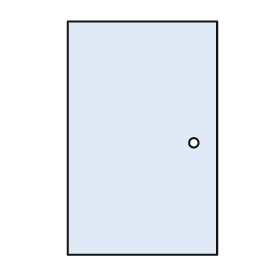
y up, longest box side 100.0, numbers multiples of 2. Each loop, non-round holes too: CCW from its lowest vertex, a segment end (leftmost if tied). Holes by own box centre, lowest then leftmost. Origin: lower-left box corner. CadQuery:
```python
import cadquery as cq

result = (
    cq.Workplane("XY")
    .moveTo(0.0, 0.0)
    .lineTo(64.0, 0.0)
    .lineTo(64.0, 100.0)
    .lineTo(0.0, 100.0)
    .close()
    .moveTo(54.0, 48.0)
    .circle(2.0)
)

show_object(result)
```